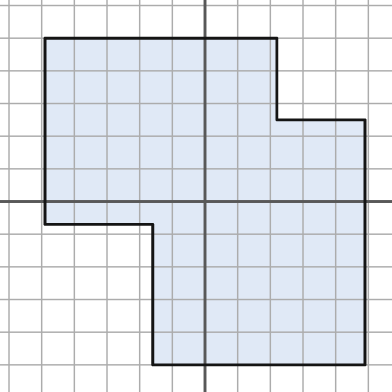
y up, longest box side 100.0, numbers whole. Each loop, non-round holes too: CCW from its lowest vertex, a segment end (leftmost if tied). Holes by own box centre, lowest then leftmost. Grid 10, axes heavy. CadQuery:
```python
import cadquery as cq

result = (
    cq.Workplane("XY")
    .moveTo(-16.0, -50.0)
    .lineTo(49.0, -50.0)
    .lineTo(49.0, 25.0)
    .lineTo(22.0, 25.0)
    .lineTo(22.0, 50.0)
    .lineTo(-49.0, 50.0)
    .lineTo(-49.0, -7.0)
    .lineTo(-16.0, -7.0)
    .close()
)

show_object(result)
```